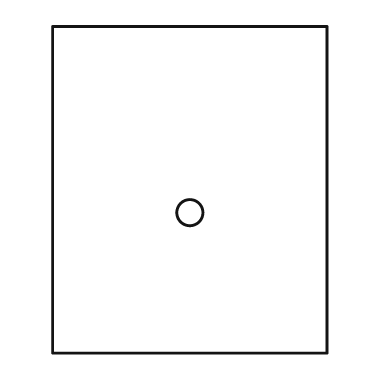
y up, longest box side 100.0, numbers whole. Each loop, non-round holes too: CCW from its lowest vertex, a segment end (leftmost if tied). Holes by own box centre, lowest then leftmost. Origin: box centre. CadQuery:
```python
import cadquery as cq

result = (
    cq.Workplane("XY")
    .moveTo(-42.0, -50.0)
    .lineTo(42.0, -50.0)
    .lineTo(42.0, 50.0)
    .lineTo(-42.0, 50.0)
    .close()
    .moveTo(0.0, -7.0)
    .circle(4.0)
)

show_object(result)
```